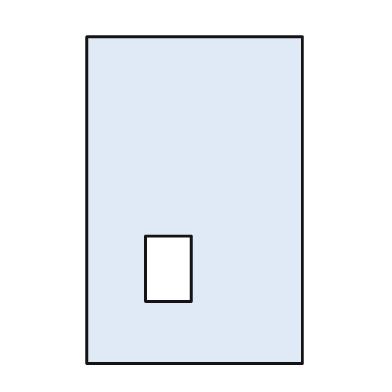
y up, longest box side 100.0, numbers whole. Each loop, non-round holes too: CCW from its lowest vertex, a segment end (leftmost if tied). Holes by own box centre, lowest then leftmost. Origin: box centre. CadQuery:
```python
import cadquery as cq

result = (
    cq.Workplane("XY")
    .moveTo(-33.0, -50.0)
    .lineTo(33.0, -50.0)
    .lineTo(33.0, 50.0)
    .lineTo(-33.0, 50.0)
    .close()
    .moveTo(-15.0, -31.0)
    .lineTo(-1.0, -31.0)
    .lineTo(-1.0, -11.0)
    .lineTo(-15.0, -11.0)
    .close()
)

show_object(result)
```